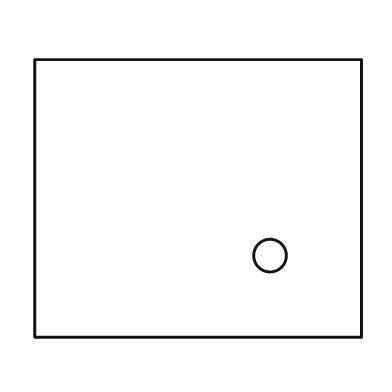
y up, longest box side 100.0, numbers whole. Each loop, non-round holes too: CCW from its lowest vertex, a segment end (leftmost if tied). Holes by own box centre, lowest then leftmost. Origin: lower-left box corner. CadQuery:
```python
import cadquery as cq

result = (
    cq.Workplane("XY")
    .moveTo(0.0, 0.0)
    .lineTo(100.0, 0.0)
    .lineTo(100.0, 85.0)
    .lineTo(0.0, 85.0)
    .close()
    .moveTo(72.0, 25.0)
    .circle(5.0)
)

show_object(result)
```